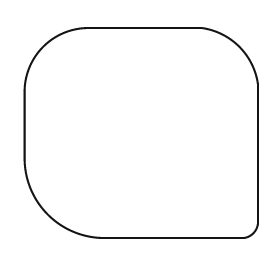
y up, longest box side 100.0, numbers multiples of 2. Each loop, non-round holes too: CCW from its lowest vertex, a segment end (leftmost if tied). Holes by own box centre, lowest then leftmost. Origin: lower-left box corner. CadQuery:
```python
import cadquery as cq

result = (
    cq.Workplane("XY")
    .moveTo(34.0, 0.0)
    .lineTo(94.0, 0.0)
    .threePointArc((98.0, 2.0), (100.0, 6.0))
    .lineTo(100.0, 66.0)
    .threePointArc((92.0, 82.0), (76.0, 90.0))
    .lineTo(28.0, 90.0)
    .threePointArc((8.0, 82.0), (0.0, 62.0))
    .lineTo(0.0, 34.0)
    .threePointArc((10.0, 10.0), (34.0, 0.0))
    .close()
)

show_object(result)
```